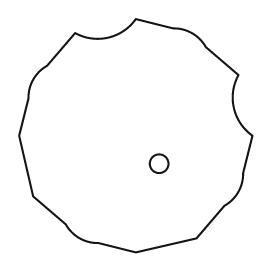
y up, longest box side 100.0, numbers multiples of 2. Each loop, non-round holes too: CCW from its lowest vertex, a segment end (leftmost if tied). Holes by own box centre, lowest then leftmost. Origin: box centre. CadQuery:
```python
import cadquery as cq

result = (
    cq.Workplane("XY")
    .moveTo(0.0, -50.0)
    .lineTo(26.0, -44.0)
    .lineTo(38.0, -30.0)
    .threePointArc((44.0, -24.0), (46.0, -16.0))
    .lineTo(50.0, 0.0)
    .threePointArc((42.0, 12.0), (44.0, 26.0))
    .lineTo(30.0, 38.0)
    .threePointArc((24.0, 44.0), (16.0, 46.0))
    .lineTo(0.0, 50.0)
    .threePointArc((-12.0, 42.0), (-26.0, 44.0))
    .lineTo(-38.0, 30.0)
    .threePointArc((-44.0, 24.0), (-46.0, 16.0))
    .lineTo(-50.0, 0.0)
    .lineTo(-44.0, -26.0)
    .lineTo(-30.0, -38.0)
    .threePointArc((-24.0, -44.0), (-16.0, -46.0))
    .close()
    .moveTo(10.0, -12.0)
    .circle(4.0)
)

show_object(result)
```